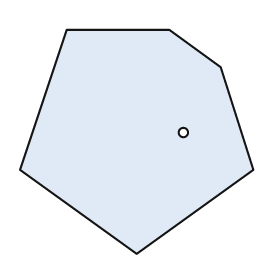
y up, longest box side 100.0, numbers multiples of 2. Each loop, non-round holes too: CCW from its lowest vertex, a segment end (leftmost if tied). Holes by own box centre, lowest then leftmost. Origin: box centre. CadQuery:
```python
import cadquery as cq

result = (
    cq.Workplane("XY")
    .moveTo(0.0, -48.0)
    .lineTo(50.0, -12.0)
    .lineTo(36.0, 32.0)
    .lineTo(14.0, 48.0)
    .lineTo(-30.0, 48.0)
    .lineTo(-50.0, -12.0)
    .close()
    .moveTo(20.0, 4.0)
    .circle(2.0)
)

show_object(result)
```